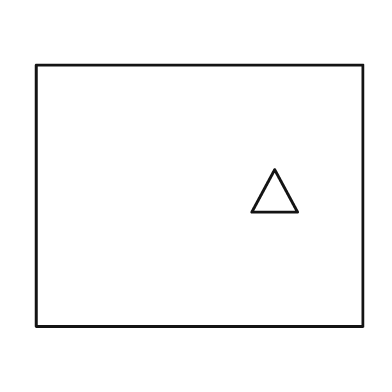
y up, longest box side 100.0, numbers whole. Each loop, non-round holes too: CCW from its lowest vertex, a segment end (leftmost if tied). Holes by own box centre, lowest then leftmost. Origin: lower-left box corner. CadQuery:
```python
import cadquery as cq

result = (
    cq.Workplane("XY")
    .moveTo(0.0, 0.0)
    .lineTo(100.0, 0.0)
    .lineTo(100.0, 80.0)
    .lineTo(0.0, 80.0)
    .close()
    .moveTo(66.0, 35.0)
    .lineTo(80.0, 35.0)
    .lineTo(73.0, 48.0)
    .close()
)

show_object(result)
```